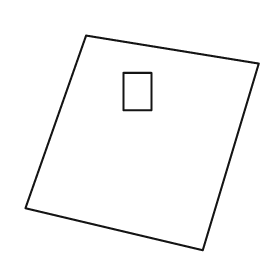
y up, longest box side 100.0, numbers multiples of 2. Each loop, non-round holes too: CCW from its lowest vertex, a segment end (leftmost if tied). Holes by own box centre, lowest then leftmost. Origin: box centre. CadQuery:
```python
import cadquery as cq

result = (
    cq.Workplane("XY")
    .moveTo(26.0, -46.0)
    .lineTo(50.0, 34.0)
    .lineTo(-24.0, 46.0)
    .lineTo(-50.0, -28.0)
    .close()
    .moveTo(-8.0, 14.0)
    .lineTo(4.0, 14.0)
    .lineTo(4.0, 30.0)
    .lineTo(-8.0, 30.0)
    .close()
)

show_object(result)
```